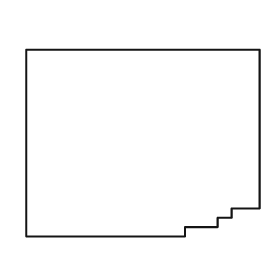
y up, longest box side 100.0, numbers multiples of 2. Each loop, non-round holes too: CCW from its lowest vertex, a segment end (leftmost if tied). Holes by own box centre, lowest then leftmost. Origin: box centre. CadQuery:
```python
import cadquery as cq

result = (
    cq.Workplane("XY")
    .moveTo(-50.0, -40.0)
    .lineTo(18.0, -40.0)
    .lineTo(18.0, -36.0)
    .lineTo(32.0, -36.0)
    .lineTo(32.0, -32.0)
    .lineTo(38.0, -32.0)
    .lineTo(38.0, -28.0)
    .lineTo(50.0, -28.0)
    .lineTo(50.0, 40.0)
    .lineTo(-50.0, 40.0)
    .close()
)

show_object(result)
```